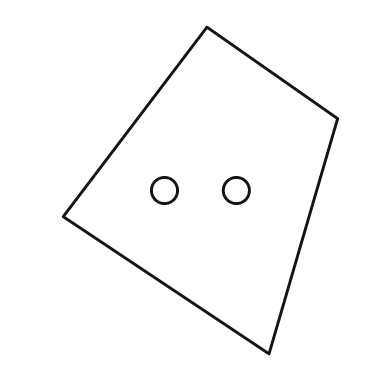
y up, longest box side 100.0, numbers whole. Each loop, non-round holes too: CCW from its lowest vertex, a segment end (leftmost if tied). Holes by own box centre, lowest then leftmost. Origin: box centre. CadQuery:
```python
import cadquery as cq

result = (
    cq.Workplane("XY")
    .moveTo(21.0, -50.0)
    .lineTo(42.0, 22.0)
    .lineTo(2.0, 50.0)
    .lineTo(-42.0, -8.0)
    .close()
    .moveTo(-11.0, 0.0)
    .circle(4.0)
    .moveTo(11.0, 0.0)
    .circle(4.0)
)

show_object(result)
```